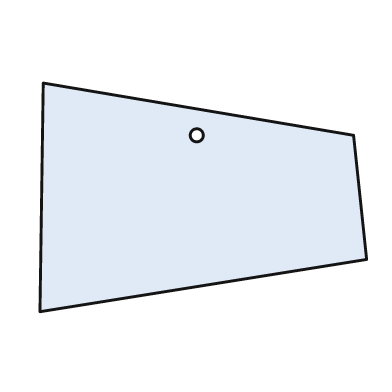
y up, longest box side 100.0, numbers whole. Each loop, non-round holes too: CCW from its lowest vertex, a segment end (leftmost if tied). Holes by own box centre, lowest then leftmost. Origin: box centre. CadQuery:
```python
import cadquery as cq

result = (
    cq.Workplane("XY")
    .moveTo(-50.0, -35.0)
    .lineTo(50.0, -19.0)
    .lineTo(46.0, 19.0)
    .lineTo(-49.0, 35.0)
    .close()
    .moveTo(-2.0, 19.0)
    .circle(2.0)
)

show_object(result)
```